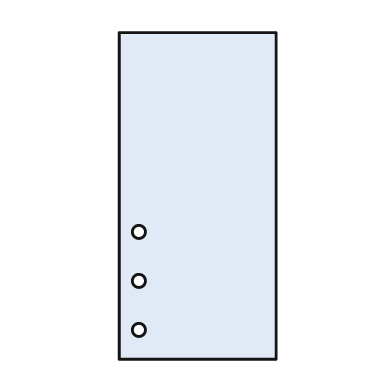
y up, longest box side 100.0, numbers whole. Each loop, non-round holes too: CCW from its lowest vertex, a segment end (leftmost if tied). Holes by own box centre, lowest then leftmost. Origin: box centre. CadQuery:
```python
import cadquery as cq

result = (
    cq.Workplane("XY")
    .moveTo(-24.0, -50.0)
    .lineTo(24.0, -50.0)
    .lineTo(24.0, 50.0)
    .lineTo(-24.0, 50.0)
    .close()
    .moveTo(-18.0, -41.0)
    .circle(2.0)
    .moveTo(-18.0, -26.0)
    .circle(2.0)
    .moveTo(-18.0, -11.0)
    .circle(2.0)
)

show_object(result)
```